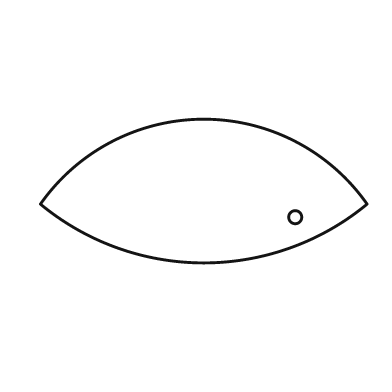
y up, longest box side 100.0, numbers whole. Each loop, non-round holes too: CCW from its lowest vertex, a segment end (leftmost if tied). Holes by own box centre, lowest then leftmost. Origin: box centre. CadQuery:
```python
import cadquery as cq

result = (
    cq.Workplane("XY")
    .moveTo(-50.0, -4.0)
    .threePointArc((0.0, -22.0), (50.0, -4.0))
    .threePointArc((0.0, 22.0), (-50.0, -4.0))
    .close()
    .moveTo(28.0, -8.0)
    .circle(2.0)
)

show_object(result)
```